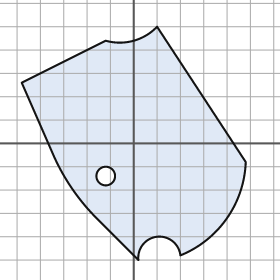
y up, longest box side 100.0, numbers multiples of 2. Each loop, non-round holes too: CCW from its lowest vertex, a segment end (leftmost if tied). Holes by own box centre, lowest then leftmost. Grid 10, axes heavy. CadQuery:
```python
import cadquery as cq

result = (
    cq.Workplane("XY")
    .moveTo(2.0, -50.0)
    .threePointArc((10.0, -40.0), (20.0, -48.0))
    .threePointArc((40.0, -32.0), (48.0, -8.0))
    .lineTo(10.0, 50.0)
    .threePointArc((0.0, 44.0), (-12.0, 44.0))
    .lineTo(-48.0, 26.0)
    .lineTo(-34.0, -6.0)
    .threePointArc((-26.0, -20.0), (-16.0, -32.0))
    .close()
    .moveTo(-12.0, -14.0)
    .circle(4.0)
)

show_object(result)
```